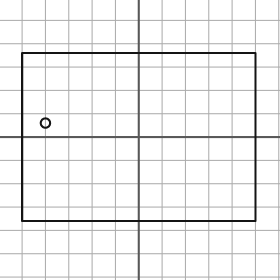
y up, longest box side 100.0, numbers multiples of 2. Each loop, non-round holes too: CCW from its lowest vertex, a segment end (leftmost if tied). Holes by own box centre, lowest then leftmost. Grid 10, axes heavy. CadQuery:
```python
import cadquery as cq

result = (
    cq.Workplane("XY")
    .moveTo(-50.0, -36.0)
    .lineTo(50.0, -36.0)
    .lineTo(50.0, 36.0)
    .lineTo(-50.0, 36.0)
    .close()
    .moveTo(-40.0, 6.0)
    .circle(2.0)
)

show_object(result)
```